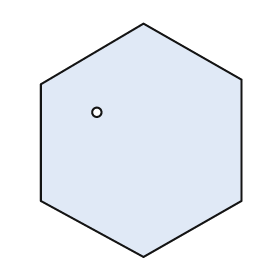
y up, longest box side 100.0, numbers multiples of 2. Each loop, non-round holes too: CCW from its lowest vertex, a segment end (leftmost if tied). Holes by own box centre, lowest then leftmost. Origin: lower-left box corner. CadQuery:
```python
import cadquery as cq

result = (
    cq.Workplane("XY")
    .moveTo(44.0, 0.0)
    .lineTo(86.0, 24.0)
    .lineTo(86.0, 76.0)
    .lineTo(44.0, 100.0)
    .lineTo(0.0, 74.0)
    .lineTo(0.0, 24.0)
    .close()
    .moveTo(24.0, 62.0)
    .circle(2.0)
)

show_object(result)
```